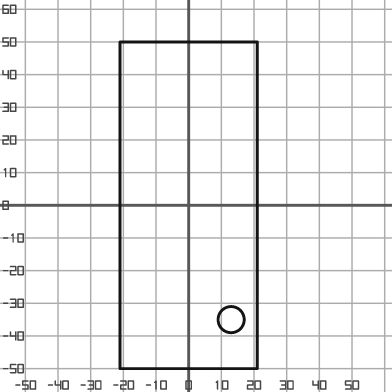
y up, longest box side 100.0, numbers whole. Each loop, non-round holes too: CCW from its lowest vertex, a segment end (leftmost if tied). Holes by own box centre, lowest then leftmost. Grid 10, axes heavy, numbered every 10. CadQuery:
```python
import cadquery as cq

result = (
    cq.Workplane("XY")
    .moveTo(-21.0, -50.0)
    .lineTo(21.0, -50.0)
    .lineTo(21.0, 50.0)
    .lineTo(-21.0, 50.0)
    .close()
    .moveTo(13.0, -35.0)
    .circle(4.0)
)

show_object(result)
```